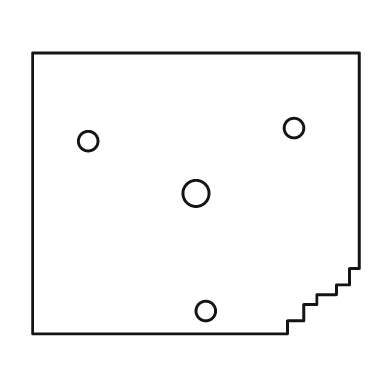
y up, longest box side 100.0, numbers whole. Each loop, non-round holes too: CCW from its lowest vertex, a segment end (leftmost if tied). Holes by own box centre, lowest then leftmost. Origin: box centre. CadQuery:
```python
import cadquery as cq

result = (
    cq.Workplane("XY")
    .moveTo(-50.0, -43.0)
    .lineTo(28.0, -43.0)
    .lineTo(28.0, -39.0)
    .lineTo(33.0, -39.0)
    .lineTo(33.0, -34.0)
    .lineTo(37.0, -34.0)
    .lineTo(37.0, -31.0)
    .lineTo(43.0, -31.0)
    .lineTo(43.0, -28.0)
    .lineTo(47.0, -28.0)
    .lineTo(47.0, -23.0)
    .lineTo(50.0, -23.0)
    .lineTo(50.0, 43.0)
    .lineTo(-50.0, 43.0)
    .close()
    .moveTo(3.0, -36.0)
    .circle(3.0)
    .moveTo(0.0, 0.0)
    .circle(4.0)
    .moveTo(-33.0, 16.0)
    .circle(3.0)
    .moveTo(30.0, 20.0)
    .circle(3.0)
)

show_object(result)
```